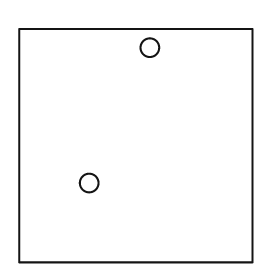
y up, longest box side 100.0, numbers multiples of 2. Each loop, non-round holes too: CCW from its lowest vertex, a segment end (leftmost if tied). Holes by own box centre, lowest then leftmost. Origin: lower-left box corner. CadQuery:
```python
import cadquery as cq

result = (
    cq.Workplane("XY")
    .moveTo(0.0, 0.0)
    .lineTo(100.0, 0.0)
    .lineTo(100.0, 100.0)
    .lineTo(0.0, 100.0)
    .close()
    .moveTo(30.0, 34.0)
    .circle(4.0)
    .moveTo(56.0, 92.0)
    .circle(4.0)
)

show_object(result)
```